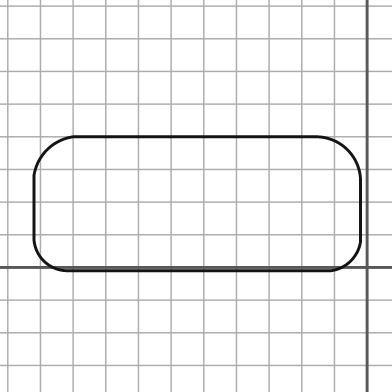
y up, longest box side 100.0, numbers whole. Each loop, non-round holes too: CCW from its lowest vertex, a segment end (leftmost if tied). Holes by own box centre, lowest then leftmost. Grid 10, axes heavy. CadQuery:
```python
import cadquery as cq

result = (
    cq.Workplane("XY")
    .moveTo(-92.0, -1.0)
    .lineTo(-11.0, -1.0)
    .threePointArc((-5.0, 2.0), (-2.0, 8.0))
    .lineTo(-2.0, 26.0)
    .threePointArc((-6.0, 36.0), (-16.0, 40.0))
    .lineTo(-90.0, 40.0)
    .threePointArc((-98.0, 36.0), (-102.0, 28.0))
    .lineTo(-102.0, 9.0)
    .threePointArc((-99.0, 2.0), (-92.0, -1.0))
    .close()
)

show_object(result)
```